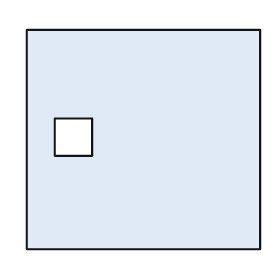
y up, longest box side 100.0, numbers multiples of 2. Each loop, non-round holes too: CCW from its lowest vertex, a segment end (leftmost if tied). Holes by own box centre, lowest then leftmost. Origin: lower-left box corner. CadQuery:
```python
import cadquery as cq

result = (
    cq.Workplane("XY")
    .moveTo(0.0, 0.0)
    .lineTo(100.0, 0.0)
    .lineTo(100.0, 94.0)
    .lineTo(0.0, 94.0)
    .close()
    .moveTo(12.0, 40.0)
    .lineTo(28.0, 40.0)
    .lineTo(28.0, 56.0)
    .lineTo(12.0, 56.0)
    .close()
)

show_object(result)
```